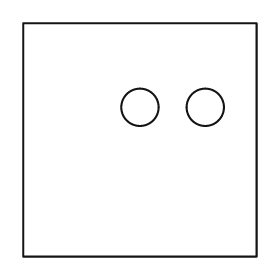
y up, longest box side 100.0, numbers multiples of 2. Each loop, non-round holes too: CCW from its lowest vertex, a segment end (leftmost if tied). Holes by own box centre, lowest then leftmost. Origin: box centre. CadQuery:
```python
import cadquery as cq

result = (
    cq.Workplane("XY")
    .moveTo(-50.0, -50.0)
    .lineTo(50.0, -50.0)
    .lineTo(50.0, 50.0)
    .lineTo(-50.0, 50.0)
    .close()
    .moveTo(0.0, 14.0)
    .circle(8.0)
    .moveTo(28.0, 14.0)
    .circle(8.0)
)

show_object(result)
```